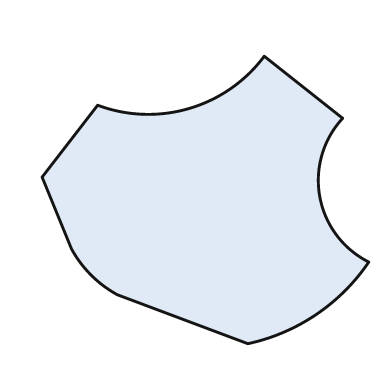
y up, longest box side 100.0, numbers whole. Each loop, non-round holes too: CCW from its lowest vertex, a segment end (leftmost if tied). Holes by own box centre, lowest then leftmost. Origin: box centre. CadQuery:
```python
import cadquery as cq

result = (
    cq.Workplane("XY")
    .moveTo(13.0, -44.0)
    .threePointArc((34.0, -35.0), (50.0, -19.0))
    .threePointArc((35.0, 1.0), (42.0, 25.0))
    .lineTo(18.0, 44.0)
    .threePointArc((-5.0, 28.0), (-33.0, 29.0))
    .lineTo(-50.0, 7.0)
    .lineTo(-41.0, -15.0)
    .threePointArc((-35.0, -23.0), (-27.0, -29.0))
    .close()
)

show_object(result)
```